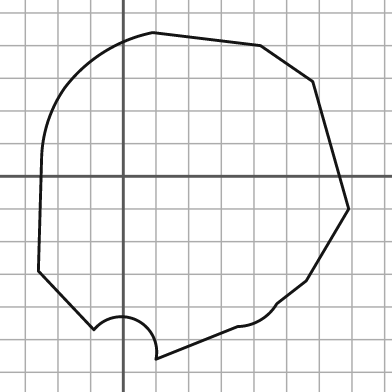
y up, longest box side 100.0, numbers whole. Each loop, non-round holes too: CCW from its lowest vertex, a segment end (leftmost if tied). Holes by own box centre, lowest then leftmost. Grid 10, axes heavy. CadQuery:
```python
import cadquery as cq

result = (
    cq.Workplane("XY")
    .moveTo(10.0, -56.0)
    .lineTo(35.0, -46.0)
    .threePointArc((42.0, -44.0), (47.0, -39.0))
    .lineTo(56.0, -32.0)
    .lineTo(69.0, -10.0)
    .lineTo(58.0, 29.0)
    .lineTo(42.0, 40.0)
    .lineTo(9.0, 44.0)
    .threePointArc((-6.0, 38.0), (-18.0, 27.0))
    .threePointArc((-23.0, 17.0), (-25.0, 6.0))
    .lineTo(-26.0, -29.0)
    .lineTo(-9.0, -47.0)
    .threePointArc((4.0, -44.0), (10.0, -56.0))
    .close()
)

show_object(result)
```